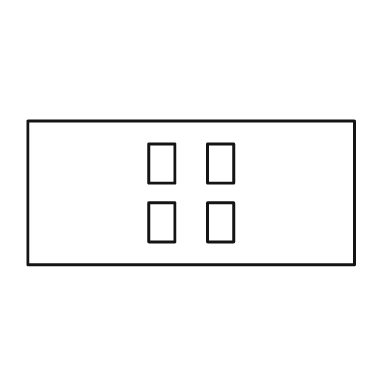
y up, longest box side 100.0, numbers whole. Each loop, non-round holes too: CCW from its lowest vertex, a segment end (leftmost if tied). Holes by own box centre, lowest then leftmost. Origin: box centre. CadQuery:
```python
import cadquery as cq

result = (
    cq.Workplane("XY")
    .moveTo(-50.0, -22.0)
    .lineTo(50.0, -22.0)
    .lineTo(50.0, 22.0)
    .lineTo(-50.0, 22.0)
    .close()
    .moveTo(-13.0, -15.0)
    .lineTo(-5.0, -15.0)
    .lineTo(-5.0, -3.0)
    .lineTo(-13.0, -3.0)
    .close()
    .moveTo(5.0, -15.0)
    .lineTo(13.0, -15.0)
    .lineTo(13.0, -3.0)
    .lineTo(5.0, -3.0)
    .close()
    .moveTo(-13.0, 3.0)
    .lineTo(-5.0, 3.0)
    .lineTo(-5.0, 15.0)
    .lineTo(-13.0, 15.0)
    .close()
    .moveTo(5.0, 3.0)
    .lineTo(13.0, 3.0)
    .lineTo(13.0, 15.0)
    .lineTo(5.0, 15.0)
    .close()
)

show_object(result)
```